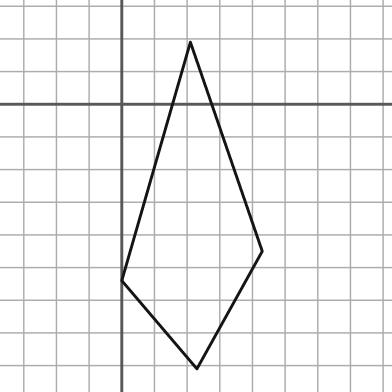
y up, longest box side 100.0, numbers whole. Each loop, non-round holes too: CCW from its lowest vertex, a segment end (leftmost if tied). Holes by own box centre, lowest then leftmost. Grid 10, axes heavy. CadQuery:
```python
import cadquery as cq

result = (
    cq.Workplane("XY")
    .moveTo(23.0, -81.0)
    .lineTo(43.0, -45.0)
    .lineTo(21.0, 19.0)
    .lineTo(0.0, -54.0)
    .close()
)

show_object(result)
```